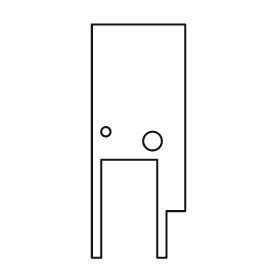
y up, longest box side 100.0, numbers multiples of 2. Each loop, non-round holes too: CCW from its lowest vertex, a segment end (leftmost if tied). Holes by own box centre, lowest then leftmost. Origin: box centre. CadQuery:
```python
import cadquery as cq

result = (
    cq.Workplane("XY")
    .moveTo(-20.0, -50.0)
    .lineTo(-16.0, -50.0)
    .lineTo(-16.0, -8.0)
    .lineTo(8.0, -8.0)
    .lineTo(8.0, -50.0)
    .lineTo(12.0, -50.0)
    .lineTo(12.0, -30.0)
    .lineTo(20.0, -30.0)
    .lineTo(20.0, 50.0)
    .lineTo(-20.0, 50.0)
    .close()
    .moveTo(6.0, 0.0)
    .circle(4.0)
    .moveTo(-14.0, 4.0)
    .circle(2.0)
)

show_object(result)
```